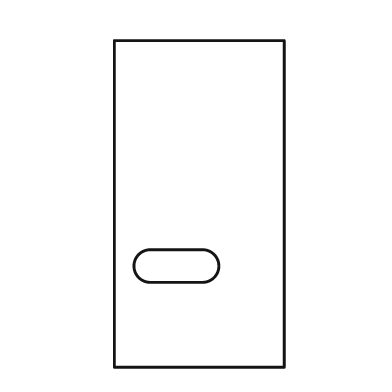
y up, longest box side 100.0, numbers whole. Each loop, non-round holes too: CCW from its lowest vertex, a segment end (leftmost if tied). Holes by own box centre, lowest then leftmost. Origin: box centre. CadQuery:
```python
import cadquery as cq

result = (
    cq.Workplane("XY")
    .moveTo(-26.0, -50.0)
    .lineTo(26.0, -50.0)
    .lineTo(26.0, 50.0)
    .lineTo(-26.0, 50.0)
    .close()
    .moveTo(-15.0, -24.0)
    .lineTo(1.0, -24.0)
    .threePointArc((6.0, -19.0), (1.0, -14.0))
    .lineTo(-15.0, -14.0)
    .threePointArc((-20.0, -19.0), (-15.0, -24.0))
    .close()
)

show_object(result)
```